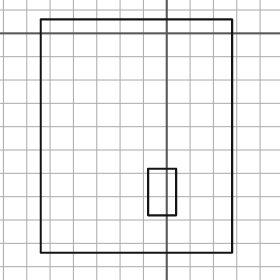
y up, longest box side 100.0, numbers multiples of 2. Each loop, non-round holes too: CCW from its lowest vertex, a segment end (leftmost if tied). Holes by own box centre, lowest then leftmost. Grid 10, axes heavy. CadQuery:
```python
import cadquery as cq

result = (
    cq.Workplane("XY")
    .moveTo(-54.0, -94.0)
    .lineTo(28.0, -94.0)
    .lineTo(28.0, 6.0)
    .lineTo(-54.0, 6.0)
    .close()
    .moveTo(-8.0, -78.0)
    .lineTo(4.0, -78.0)
    .lineTo(4.0, -58.0)
    .lineTo(-8.0, -58.0)
    .close()
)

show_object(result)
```